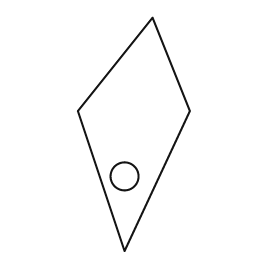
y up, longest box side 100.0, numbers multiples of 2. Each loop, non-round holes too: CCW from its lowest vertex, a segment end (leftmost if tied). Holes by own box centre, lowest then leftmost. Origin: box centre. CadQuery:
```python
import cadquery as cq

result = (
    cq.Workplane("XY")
    .moveTo(-4.0, -50.0)
    .lineTo(24.0, 10.0)
    .lineTo(8.0, 50.0)
    .lineTo(-24.0, 10.0)
    .close()
    .moveTo(-4.0, -18.0)
    .circle(6.0)
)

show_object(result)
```